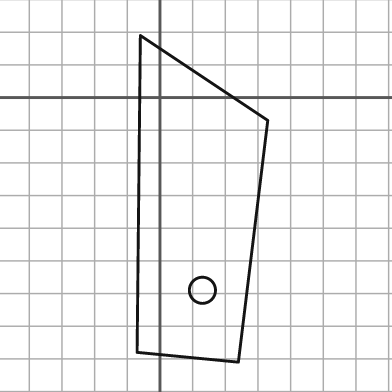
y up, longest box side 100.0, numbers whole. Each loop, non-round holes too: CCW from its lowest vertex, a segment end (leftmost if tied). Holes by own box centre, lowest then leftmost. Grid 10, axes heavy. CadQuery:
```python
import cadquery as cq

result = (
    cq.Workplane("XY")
    .moveTo(24.0, -81.0)
    .lineTo(33.0, -7.0)
    .lineTo(-6.0, 19.0)
    .lineTo(-7.0, -78.0)
    .close()
    .moveTo(13.0, -59.0)
    .circle(4.0)
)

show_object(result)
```